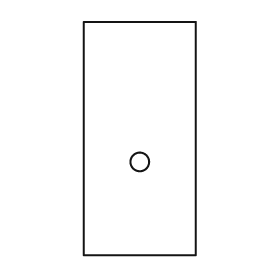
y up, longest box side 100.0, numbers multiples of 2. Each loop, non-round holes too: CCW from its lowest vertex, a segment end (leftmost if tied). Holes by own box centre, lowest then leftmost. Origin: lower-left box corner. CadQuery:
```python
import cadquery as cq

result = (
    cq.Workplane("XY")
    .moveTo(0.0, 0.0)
    .lineTo(48.0, 0.0)
    .lineTo(48.0, 100.0)
    .lineTo(0.0, 100.0)
    .close()
    .moveTo(24.0, 40.0)
    .circle(4.0)
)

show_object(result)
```